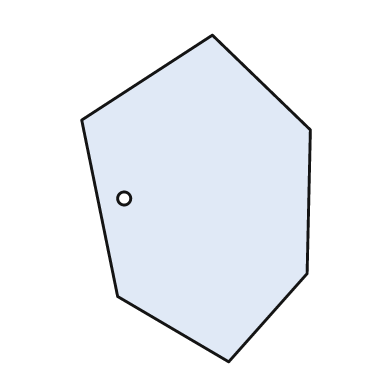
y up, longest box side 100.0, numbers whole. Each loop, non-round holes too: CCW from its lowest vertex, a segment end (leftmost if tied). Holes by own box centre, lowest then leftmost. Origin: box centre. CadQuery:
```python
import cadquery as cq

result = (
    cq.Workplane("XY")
    .moveTo(10.0, -50.0)
    .lineTo(34.0, -23.0)
    .lineTo(35.0, 21.0)
    .lineTo(5.0, 50.0)
    .lineTo(-35.0, 24.0)
    .lineTo(-24.0, -30.0)
    .close()
    .moveTo(-22.0, 0.0)
    .circle(2.0)
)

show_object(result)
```